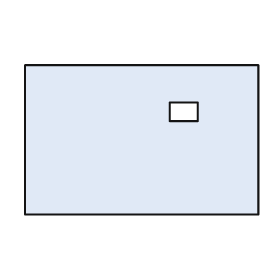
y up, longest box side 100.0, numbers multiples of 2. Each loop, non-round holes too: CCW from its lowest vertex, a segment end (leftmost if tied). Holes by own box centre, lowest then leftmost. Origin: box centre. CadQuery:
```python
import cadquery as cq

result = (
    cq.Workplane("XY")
    .moveTo(-50.0, -32.0)
    .lineTo(50.0, -32.0)
    .lineTo(50.0, 32.0)
    .lineTo(-50.0, 32.0)
    .close()
    .moveTo(12.0, 8.0)
    .lineTo(24.0, 8.0)
    .lineTo(24.0, 16.0)
    .lineTo(12.0, 16.0)
    .close()
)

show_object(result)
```